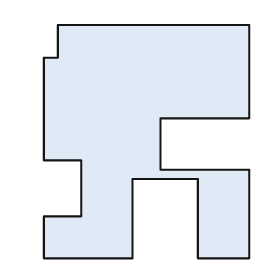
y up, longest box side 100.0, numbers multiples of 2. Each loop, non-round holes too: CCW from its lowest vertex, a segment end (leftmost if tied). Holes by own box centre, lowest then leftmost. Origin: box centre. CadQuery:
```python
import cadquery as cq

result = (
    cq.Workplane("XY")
    .moveTo(-44.0, -50.0)
    .lineTo(-6.0, -50.0)
    .lineTo(-6.0, -16.0)
    .lineTo(22.0, -16.0)
    .lineTo(22.0, -50.0)
    .lineTo(44.0, -50.0)
    .lineTo(44.0, -12.0)
    .lineTo(6.0, -12.0)
    .lineTo(6.0, 10.0)
    .lineTo(44.0, 10.0)
    .lineTo(44.0, 50.0)
    .lineTo(-38.0, 50.0)
    .lineTo(-38.0, 36.0)
    .lineTo(-44.0, 36.0)
    .lineTo(-44.0, -8.0)
    .lineTo(-28.0, -8.0)
    .lineTo(-28.0, -32.0)
    .lineTo(-44.0, -32.0)
    .close()
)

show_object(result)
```